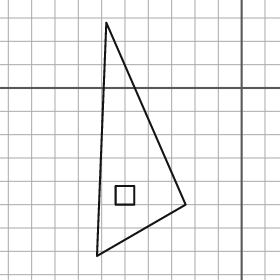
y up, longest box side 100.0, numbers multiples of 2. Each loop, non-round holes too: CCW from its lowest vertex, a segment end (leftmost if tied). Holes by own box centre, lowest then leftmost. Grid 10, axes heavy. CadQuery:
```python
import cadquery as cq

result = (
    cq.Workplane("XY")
    .moveTo(-62.0, -72.0)
    .lineTo(-24.0, -50.0)
    .lineTo(-58.0, 28.0)
    .close()
    .moveTo(-54.0, -50.0)
    .lineTo(-46.0, -50.0)
    .lineTo(-46.0, -42.0)
    .lineTo(-54.0, -42.0)
    .close()
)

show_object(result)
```